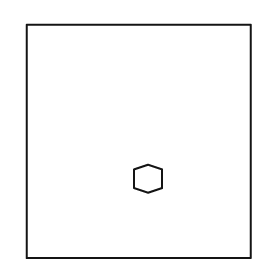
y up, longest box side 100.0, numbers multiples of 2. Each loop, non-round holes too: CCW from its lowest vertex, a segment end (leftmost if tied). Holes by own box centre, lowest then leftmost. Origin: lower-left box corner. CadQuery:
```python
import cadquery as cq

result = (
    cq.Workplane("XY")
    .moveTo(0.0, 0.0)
    .lineTo(96.0, 0.0)
    .lineTo(96.0, 100.0)
    .lineTo(0.0, 100.0)
    .close()
    .moveTo(52.0, 28.0)
    .lineTo(58.0, 30.0)
    .lineTo(58.0, 38.0)
    .lineTo(52.0, 40.0)
    .lineTo(46.0, 38.0)
    .lineTo(46.0, 30.0)
    .close()
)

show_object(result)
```